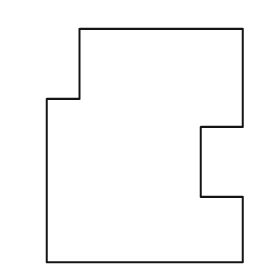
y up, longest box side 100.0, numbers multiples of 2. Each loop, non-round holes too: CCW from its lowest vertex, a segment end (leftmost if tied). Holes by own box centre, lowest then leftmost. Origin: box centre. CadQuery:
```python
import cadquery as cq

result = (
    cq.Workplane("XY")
    .moveTo(-42.0, -50.0)
    .lineTo(42.0, -50.0)
    .lineTo(42.0, -22.0)
    .lineTo(24.0, -22.0)
    .lineTo(24.0, 8.0)
    .lineTo(42.0, 8.0)
    .lineTo(42.0, 50.0)
    .lineTo(-28.0, 50.0)
    .lineTo(-28.0, 20.0)
    .lineTo(-42.0, 20.0)
    .close()
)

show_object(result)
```